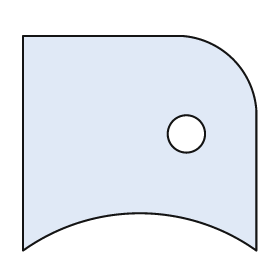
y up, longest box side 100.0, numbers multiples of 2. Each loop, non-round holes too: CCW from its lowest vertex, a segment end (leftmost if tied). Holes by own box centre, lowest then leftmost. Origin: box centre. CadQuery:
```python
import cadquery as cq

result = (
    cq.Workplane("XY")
    .moveTo(-50.0, -46.0)
    .threePointArc((0.0, -30.0), (50.0, -46.0))
    .lineTo(50.0, 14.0)
    .threePointArc((40.0, 36.0), (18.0, 46.0))
    .lineTo(-50.0, 46.0)
    .close()
    .moveTo(20.0, 4.0)
    .circle(8.0)
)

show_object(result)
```